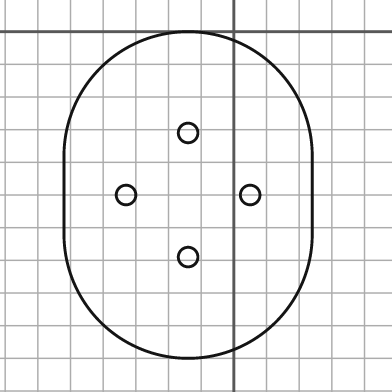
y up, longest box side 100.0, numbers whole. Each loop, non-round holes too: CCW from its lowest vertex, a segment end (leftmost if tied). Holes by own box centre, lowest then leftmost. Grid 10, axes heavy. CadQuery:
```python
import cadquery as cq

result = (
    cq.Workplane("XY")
    .moveTo(-52.0, -62.0)
    .threePointArc((-14.0, -100.0), (24.0, -62.0))
    .lineTo(24.0, -38.0)
    .threePointArc((-14.0, 0.0), (-52.0, -38.0))
    .close()
    .moveTo(-14.0, -69.0)
    .circle(3.0)
    .moveTo(-33.0, -50.0)
    .circle(3.0)
    .moveTo(5.0, -50.0)
    .circle(3.0)
    .moveTo(-14.0, -31.0)
    .circle(3.0)
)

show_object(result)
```